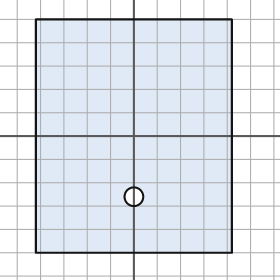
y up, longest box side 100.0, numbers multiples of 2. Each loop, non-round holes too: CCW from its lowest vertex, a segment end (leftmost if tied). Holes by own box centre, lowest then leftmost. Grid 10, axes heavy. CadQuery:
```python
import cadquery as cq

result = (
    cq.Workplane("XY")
    .moveTo(-42.0, -50.0)
    .lineTo(42.0, -50.0)
    .lineTo(42.0, 50.0)
    .lineTo(-42.0, 50.0)
    .close()
    .moveTo(0.0, -26.0)
    .circle(4.0)
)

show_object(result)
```